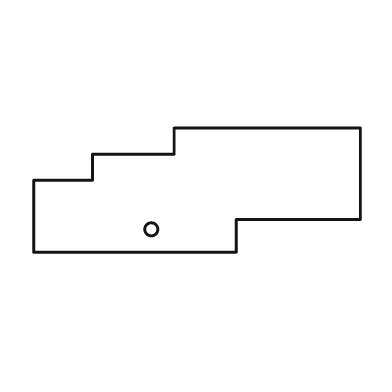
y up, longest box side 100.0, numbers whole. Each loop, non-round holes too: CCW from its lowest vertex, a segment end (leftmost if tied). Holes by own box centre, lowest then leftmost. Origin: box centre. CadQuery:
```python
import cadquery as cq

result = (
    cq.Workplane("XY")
    .moveTo(-50.0, -19.0)
    .lineTo(12.0, -19.0)
    .lineTo(12.0, -9.0)
    .lineTo(50.0, -9.0)
    .lineTo(50.0, 19.0)
    .lineTo(-7.0, 19.0)
    .lineTo(-7.0, 11.0)
    .lineTo(-32.0, 11.0)
    .lineTo(-32.0, 3.0)
    .lineTo(-50.0, 3.0)
    .close()
    .moveTo(-14.0, -12.0)
    .circle(2.0)
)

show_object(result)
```